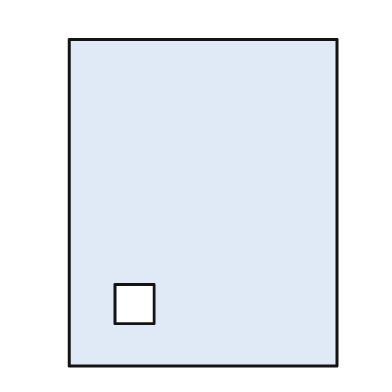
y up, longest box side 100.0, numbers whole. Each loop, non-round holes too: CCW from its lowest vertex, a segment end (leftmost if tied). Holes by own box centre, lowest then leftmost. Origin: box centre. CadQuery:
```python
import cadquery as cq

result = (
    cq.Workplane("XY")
    .moveTo(-41.0, -50.0)
    .lineTo(41.0, -50.0)
    .lineTo(41.0, 50.0)
    .lineTo(-41.0, 50.0)
    .close()
    .moveTo(-27.0, -37.0)
    .lineTo(-15.0, -37.0)
    .lineTo(-15.0, -25.0)
    .lineTo(-27.0, -25.0)
    .close()
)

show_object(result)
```